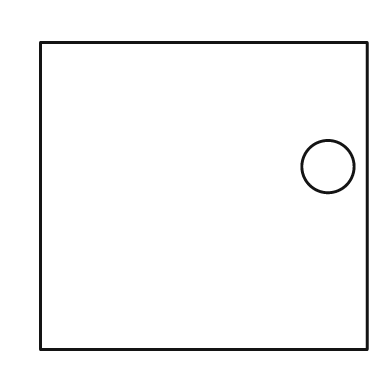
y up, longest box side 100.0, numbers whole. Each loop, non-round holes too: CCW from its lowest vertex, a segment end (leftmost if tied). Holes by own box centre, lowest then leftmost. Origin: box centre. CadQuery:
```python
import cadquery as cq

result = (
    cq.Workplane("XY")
    .moveTo(-50.0, -47.0)
    .lineTo(50.0, -47.0)
    .lineTo(50.0, 47.0)
    .lineTo(-50.0, 47.0)
    .close()
    .moveTo(38.0, 9.0)
    .circle(8.0)
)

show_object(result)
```